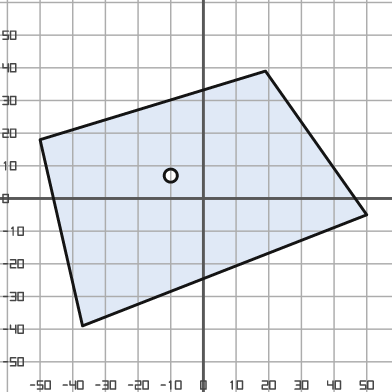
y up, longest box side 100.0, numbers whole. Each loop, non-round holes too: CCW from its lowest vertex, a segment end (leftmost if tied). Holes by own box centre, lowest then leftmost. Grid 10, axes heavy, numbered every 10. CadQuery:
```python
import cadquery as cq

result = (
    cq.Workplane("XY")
    .moveTo(-37.0, -39.0)
    .lineTo(50.0, -5.0)
    .lineTo(19.0, 39.0)
    .lineTo(-50.0, 18.0)
    .close()
    .moveTo(-10.0, 7.0)
    .circle(2.0)
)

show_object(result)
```